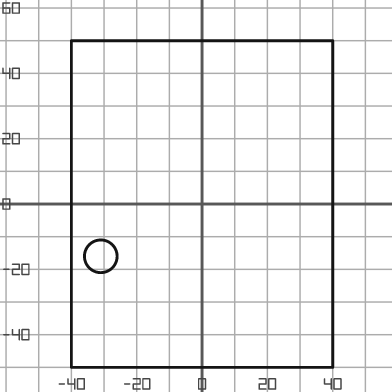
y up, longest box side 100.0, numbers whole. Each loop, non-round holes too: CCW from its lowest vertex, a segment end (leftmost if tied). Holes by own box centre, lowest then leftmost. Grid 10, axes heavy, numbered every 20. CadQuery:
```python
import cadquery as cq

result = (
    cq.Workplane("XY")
    .moveTo(-40.0, -50.0)
    .lineTo(40.0, -50.0)
    .lineTo(40.0, 50.0)
    .lineTo(-40.0, 50.0)
    .close()
    .moveTo(-31.0, -16.0)
    .circle(5.0)
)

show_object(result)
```